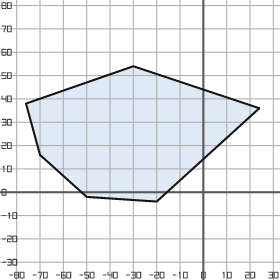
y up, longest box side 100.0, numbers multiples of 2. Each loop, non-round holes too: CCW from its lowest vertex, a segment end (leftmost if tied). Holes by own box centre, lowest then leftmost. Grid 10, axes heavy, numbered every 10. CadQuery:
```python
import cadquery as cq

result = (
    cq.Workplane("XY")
    .moveTo(-20.0, -4.0)
    .lineTo(24.0, 36.0)
    .lineTo(-30.0, 54.0)
    .lineTo(-76.0, 38.0)
    .lineTo(-70.0, 16.0)
    .lineTo(-50.0, -2.0)
    .close()
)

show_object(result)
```